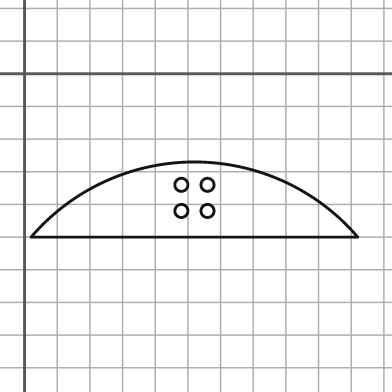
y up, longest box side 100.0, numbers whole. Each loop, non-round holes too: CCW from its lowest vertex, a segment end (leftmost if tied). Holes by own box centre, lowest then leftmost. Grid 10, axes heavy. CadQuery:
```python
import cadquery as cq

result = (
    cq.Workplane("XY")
    .moveTo(2.0, -50.0)
    .lineTo(102.0, -50.0)
    .threePointArc((52.0, -27.0), (2.0, -50.0))
    .close()
    .moveTo(48.0, -42.0)
    .circle(2.0)
    .moveTo(56.0, -42.0)
    .circle(2.0)
    .moveTo(48.0, -34.0)
    .circle(2.0)
    .moveTo(56.0, -34.0)
    .circle(2.0)
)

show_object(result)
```